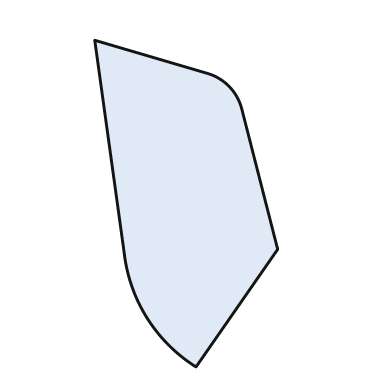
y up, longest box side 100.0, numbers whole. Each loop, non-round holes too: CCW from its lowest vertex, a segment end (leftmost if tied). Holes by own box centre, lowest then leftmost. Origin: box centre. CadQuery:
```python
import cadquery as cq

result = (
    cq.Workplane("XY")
    .moveTo(3.0, -50.0)
    .lineTo(28.0, -14.0)
    .lineTo(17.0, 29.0)
    .threePointArc((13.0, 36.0), (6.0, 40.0))
    .lineTo(-28.0, 50.0)
    .lineTo(-19.0, -15.0)
    .threePointArc((-12.0, -35.0), (3.0, -50.0))
    .close()
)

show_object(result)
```